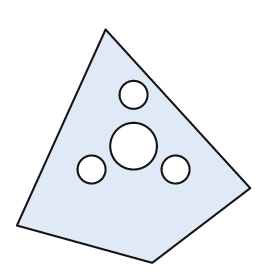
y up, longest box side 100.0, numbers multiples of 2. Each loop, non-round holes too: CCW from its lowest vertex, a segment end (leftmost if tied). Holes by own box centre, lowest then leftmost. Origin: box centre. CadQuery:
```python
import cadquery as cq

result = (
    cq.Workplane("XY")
    .moveTo(8.0, -50.0)
    .lineTo(50.0, -18.0)
    .lineTo(-12.0, 50.0)
    .lineTo(-50.0, -34.0)
    .close()
    .moveTo(-18.0, -10.0)
    .circle(6.0)
    .moveTo(18.0, -10.0)
    .circle(6.0)
    .moveTo(0.0, 0.0)
    .circle(10.0)
    .moveTo(0.0, 22.0)
    .circle(6.0)
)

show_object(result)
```